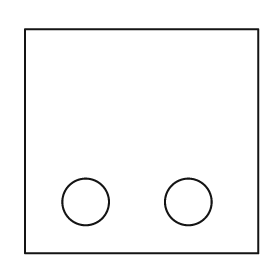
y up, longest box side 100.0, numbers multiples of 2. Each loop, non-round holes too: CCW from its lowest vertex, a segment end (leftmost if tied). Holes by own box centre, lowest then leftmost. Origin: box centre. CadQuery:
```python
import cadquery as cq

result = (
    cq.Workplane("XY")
    .moveTo(-50.0, -48.0)
    .lineTo(50.0, -48.0)
    .lineTo(50.0, 48.0)
    .lineTo(-50.0, 48.0)
    .close()
    .moveTo(-24.0, -26.0)
    .circle(10.0)
    .moveTo(20.0, -26.0)
    .circle(10.0)
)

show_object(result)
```